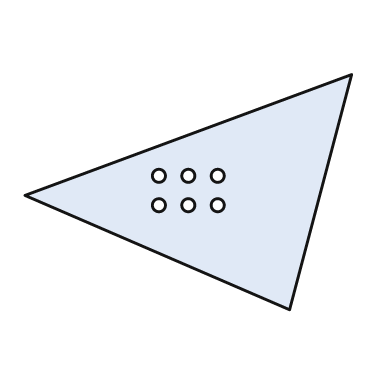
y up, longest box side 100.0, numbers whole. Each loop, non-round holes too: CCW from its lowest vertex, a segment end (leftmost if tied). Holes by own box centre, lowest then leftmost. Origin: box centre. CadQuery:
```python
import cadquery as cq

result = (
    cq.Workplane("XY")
    .moveTo(31.0, -36.0)
    .lineTo(50.0, 36.0)
    .lineTo(-50.0, -1.0)
    .close()
    .moveTo(-9.0, -4.0)
    .circle(2.0)
    .moveTo(0.0, -4.0)
    .circle(2.0)
    .moveTo(9.0, -4.0)
    .circle(2.0)
    .moveTo(-9.0, 5.0)
    .circle(2.0)
    .moveTo(0.0, 5.0)
    .circle(2.0)
    .moveTo(9.0, 5.0)
    .circle(2.0)
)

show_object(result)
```